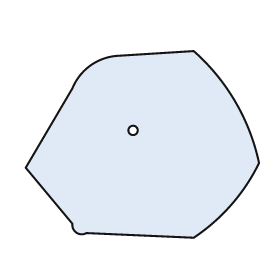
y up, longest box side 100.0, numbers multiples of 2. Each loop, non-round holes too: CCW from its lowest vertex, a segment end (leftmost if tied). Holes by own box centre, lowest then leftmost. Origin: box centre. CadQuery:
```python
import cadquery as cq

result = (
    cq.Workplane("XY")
    .moveTo(22.0, -40.0)
    .threePointArc((38.0, -26.0), (50.0, -8.0))
    .threePointArc((40.0, 18.0), (22.0, 40.0))
    .lineTo(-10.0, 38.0)
    .threePointArc((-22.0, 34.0), (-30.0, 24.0))
    .lineTo(-50.0, -10.0)
    .lineTo(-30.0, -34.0)
    .threePointArc((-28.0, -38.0), (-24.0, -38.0))
    .close()
    .moveTo(-4.0, 6.0)
    .circle(2.0)
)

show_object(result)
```